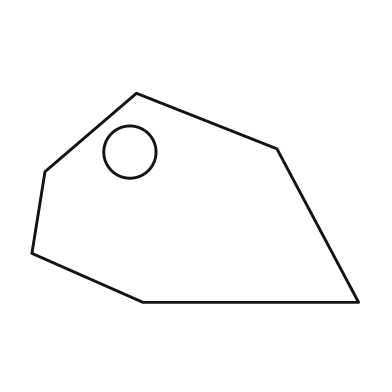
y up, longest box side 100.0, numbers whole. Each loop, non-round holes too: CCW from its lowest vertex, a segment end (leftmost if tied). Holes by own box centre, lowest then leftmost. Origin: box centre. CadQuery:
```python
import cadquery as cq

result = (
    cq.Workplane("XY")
    .moveTo(-16.0, -32.0)
    .lineTo(50.0, -32.0)
    .lineTo(25.0, 15.0)
    .lineTo(-18.0, 32.0)
    .lineTo(-46.0, 8.0)
    .lineTo(-50.0, -17.0)
    .close()
    .moveTo(-20.0, 14.0)
    .circle(8.0)
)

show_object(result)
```